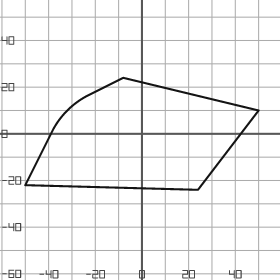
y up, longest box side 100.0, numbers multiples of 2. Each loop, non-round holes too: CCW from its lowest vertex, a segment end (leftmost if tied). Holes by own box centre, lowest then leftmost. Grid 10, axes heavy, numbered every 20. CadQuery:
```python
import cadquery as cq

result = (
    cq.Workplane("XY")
    .moveTo(24.0, -24.0)
    .lineTo(50.0, 10.0)
    .lineTo(-8.0, 24.0)
    .lineTo(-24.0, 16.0)
    .threePointArc((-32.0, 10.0), (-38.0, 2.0))
    .lineTo(-50.0, -22.0)
    .close()
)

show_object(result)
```